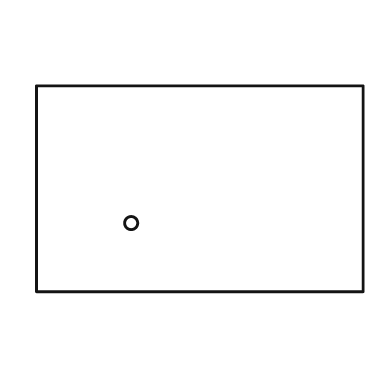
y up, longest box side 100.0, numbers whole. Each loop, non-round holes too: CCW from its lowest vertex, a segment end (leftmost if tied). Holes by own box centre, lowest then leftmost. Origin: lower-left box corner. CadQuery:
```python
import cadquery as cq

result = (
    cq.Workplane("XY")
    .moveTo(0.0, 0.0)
    .lineTo(100.0, 0.0)
    .lineTo(100.0, 63.0)
    .lineTo(0.0, 63.0)
    .close()
    .moveTo(29.0, 21.0)
    .circle(2.0)
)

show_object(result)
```